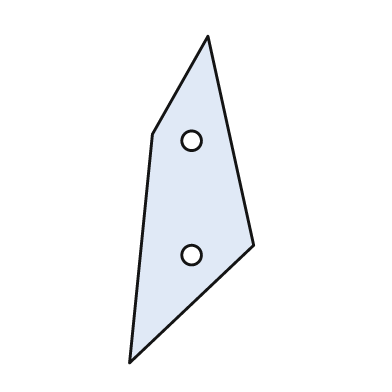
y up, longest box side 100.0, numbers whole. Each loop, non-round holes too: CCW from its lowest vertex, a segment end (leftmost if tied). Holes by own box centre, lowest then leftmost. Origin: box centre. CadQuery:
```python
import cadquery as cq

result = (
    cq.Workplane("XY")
    .moveTo(-19.0, -50.0)
    .lineTo(19.0, -14.0)
    .lineTo(5.0, 50.0)
    .lineTo(-12.0, 20.0)
    .close()
    .moveTo(0.0, -17.0)
    .circle(3.0)
    .moveTo(0.0, 18.0)
    .circle(3.0)
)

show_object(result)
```